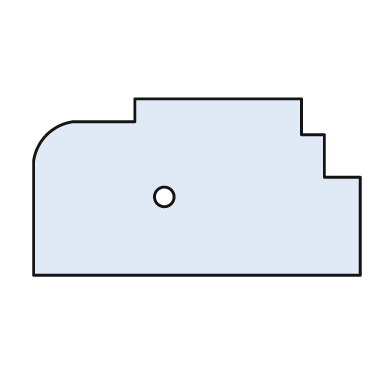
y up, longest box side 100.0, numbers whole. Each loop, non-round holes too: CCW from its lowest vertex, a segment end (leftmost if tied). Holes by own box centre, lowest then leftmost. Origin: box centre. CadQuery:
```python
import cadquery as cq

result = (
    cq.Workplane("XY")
    .moveTo(-50.0, -27.0)
    .lineTo(50.0, -27.0)
    .lineTo(50.0, 3.0)
    .lineTo(39.0, 3.0)
    .lineTo(39.0, 16.0)
    .lineTo(32.0, 16.0)
    .lineTo(32.0, 27.0)
    .lineTo(-19.0, 27.0)
    .lineTo(-19.0, 20.0)
    .lineTo(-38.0, 20.0)
    .threePointArc((-46.0, 16.0), (-50.0, 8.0))
    .close()
    .moveTo(-10.0, -3.0)
    .circle(3.0)
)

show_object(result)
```